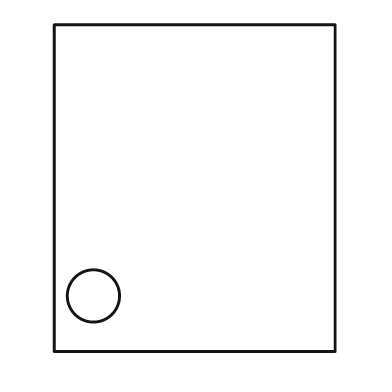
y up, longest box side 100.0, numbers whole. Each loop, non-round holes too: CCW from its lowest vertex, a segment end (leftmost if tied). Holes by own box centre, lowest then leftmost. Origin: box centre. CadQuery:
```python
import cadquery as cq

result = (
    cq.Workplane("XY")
    .moveTo(-43.0, -50.0)
    .lineTo(43.0, -50.0)
    .lineTo(43.0, 50.0)
    .lineTo(-43.0, 50.0)
    .close()
    .moveTo(-31.0, -33.0)
    .circle(8.0)
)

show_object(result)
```